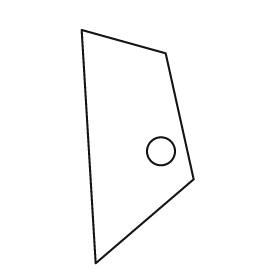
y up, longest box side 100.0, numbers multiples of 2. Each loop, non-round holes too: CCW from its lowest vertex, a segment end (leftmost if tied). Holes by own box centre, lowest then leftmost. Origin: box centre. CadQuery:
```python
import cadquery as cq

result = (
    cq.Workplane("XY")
    .moveTo(-18.0, -50.0)
    .lineTo(24.0, -14.0)
    .lineTo(12.0, 40.0)
    .lineTo(-24.0, 50.0)
    .close()
    .moveTo(10.0, -2.0)
    .circle(6.0)
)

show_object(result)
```